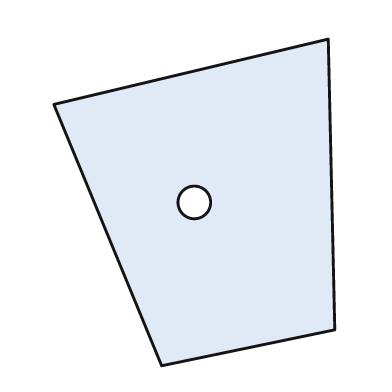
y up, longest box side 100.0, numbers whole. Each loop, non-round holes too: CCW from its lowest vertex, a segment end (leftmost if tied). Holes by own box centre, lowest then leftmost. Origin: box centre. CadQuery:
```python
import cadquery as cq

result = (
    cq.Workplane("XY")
    .moveTo(-10.0, -50.0)
    .lineTo(43.0, -39.0)
    .lineTo(41.0, 50.0)
    .lineTo(-43.0, 30.0)
    .close()
    .moveTo(0.0, 0.0)
    .circle(5.0)
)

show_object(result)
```